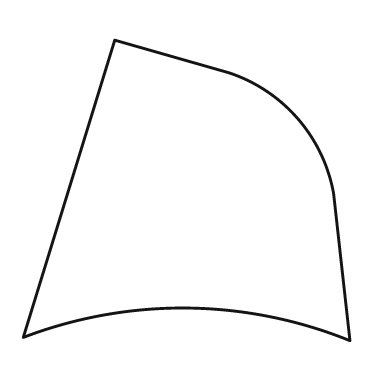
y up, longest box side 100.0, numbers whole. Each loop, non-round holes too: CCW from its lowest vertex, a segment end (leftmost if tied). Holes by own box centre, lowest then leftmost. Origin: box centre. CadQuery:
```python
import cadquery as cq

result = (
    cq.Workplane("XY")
    .moveTo(50.0, -46.0)
    .lineTo(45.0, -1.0)
    .threePointArc((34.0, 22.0), (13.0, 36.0))
    .lineTo(-22.0, 46.0)
    .lineTo(-50.0, -45.0)
    .threePointArc((0.0, -36.0), (50.0, -46.0))
    .close()
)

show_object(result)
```